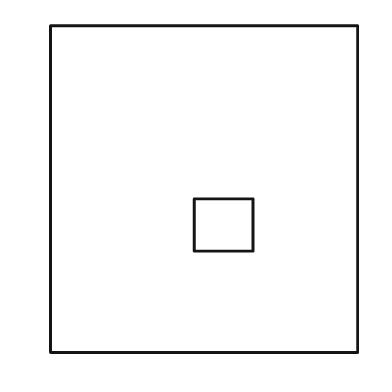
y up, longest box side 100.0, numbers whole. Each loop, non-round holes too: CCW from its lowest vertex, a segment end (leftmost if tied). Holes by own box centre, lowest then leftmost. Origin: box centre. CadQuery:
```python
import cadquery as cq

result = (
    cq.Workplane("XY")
    .moveTo(-47.0, -50.0)
    .lineTo(47.0, -50.0)
    .lineTo(47.0, 50.0)
    .lineTo(-47.0, 50.0)
    .close()
    .moveTo(-3.0, -19.0)
    .lineTo(15.0, -19.0)
    .lineTo(15.0, -3.0)
    .lineTo(-3.0, -3.0)
    .close()
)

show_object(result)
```